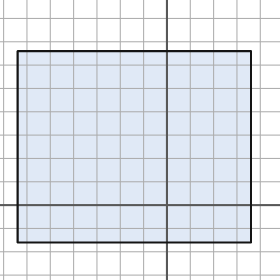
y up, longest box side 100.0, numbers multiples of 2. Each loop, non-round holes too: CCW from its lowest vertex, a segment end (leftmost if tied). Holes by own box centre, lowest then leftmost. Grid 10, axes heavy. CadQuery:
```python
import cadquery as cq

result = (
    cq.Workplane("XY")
    .moveTo(-64.0, -16.0)
    .lineTo(36.0, -16.0)
    .lineTo(36.0, 66.0)
    .lineTo(-64.0, 66.0)
    .close()
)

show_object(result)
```